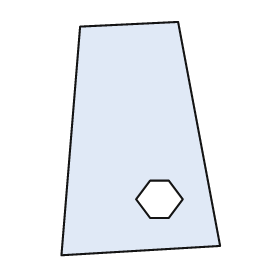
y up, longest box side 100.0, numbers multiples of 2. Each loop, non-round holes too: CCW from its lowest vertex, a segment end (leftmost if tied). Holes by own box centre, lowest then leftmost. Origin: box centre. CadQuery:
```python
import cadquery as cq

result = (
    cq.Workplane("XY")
    .moveTo(-34.0, -50.0)
    .lineTo(34.0, -46.0)
    .lineTo(16.0, 50.0)
    .lineTo(-26.0, 48.0)
    .close()
    .moveTo(4.0, -34.0)
    .lineTo(12.0, -34.0)
    .lineTo(18.0, -26.0)
    .lineTo(12.0, -18.0)
    .lineTo(4.0, -18.0)
    .lineTo(-2.0, -26.0)
    .close()
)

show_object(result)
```